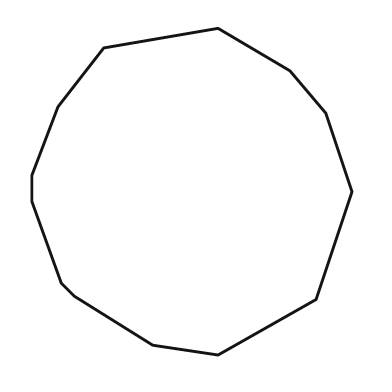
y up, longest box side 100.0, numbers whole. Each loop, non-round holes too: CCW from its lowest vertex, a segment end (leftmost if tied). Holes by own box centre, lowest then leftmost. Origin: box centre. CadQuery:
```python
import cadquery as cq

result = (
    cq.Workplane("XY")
    .moveTo(8.0, -50.0)
    .lineTo(38.0, -33.0)
    .lineTo(49.0, 0.0)
    .lineTo(41.0, 24.0)
    .lineTo(30.0, 37.0)
    .lineTo(8.0, 50.0)
    .lineTo(-27.0, 44.0)
    .lineTo(-41.0, 26.0)
    .lineTo(-49.0, 5.0)
    .lineTo(-49.0, -3.0)
    .lineTo(-40.0, -28.0)
    .lineTo(-36.0, -32.0)
    .lineTo(-12.0, -47.0)
    .close()
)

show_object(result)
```